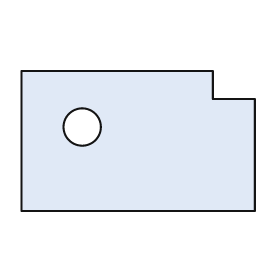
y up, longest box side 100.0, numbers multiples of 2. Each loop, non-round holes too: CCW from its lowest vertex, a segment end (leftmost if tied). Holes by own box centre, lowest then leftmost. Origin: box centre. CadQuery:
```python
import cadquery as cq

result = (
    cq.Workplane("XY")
    .moveTo(-50.0, -30.0)
    .lineTo(50.0, -30.0)
    .lineTo(50.0, 18.0)
    .lineTo(32.0, 18.0)
    .lineTo(32.0, 30.0)
    .lineTo(-50.0, 30.0)
    .close()
    .moveTo(-24.0, 6.0)
    .circle(8.0)
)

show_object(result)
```